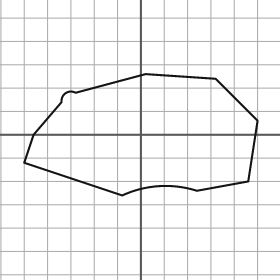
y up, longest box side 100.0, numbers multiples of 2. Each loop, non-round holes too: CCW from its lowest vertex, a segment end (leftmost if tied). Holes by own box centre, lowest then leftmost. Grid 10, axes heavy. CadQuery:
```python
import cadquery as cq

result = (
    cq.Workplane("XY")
    .moveTo(-8.0, -26.0)
    .threePointArc((8.0, -22.0), (24.0, -24.0))
    .lineTo(46.0, -20.0)
    .lineTo(50.0, 6.0)
    .lineTo(32.0, 24.0)
    .lineTo(2.0, 26.0)
    .lineTo(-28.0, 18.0)
    .threePointArc((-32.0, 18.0), (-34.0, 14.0))
    .lineTo(-46.0, 0.0)
    .lineTo(-50.0, -12.0)
    .close()
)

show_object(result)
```